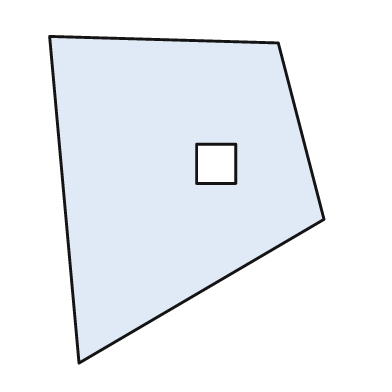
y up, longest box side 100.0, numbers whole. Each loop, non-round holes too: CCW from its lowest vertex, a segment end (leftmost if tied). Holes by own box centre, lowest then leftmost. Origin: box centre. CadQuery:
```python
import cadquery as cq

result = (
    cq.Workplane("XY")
    .moveTo(-33.0, -50.0)
    .lineTo(42.0, -6.0)
    .lineTo(28.0, 48.0)
    .lineTo(-42.0, 50.0)
    .close()
    .moveTo(3.0, 5.0)
    .lineTo(15.0, 5.0)
    .lineTo(15.0, 17.0)
    .lineTo(3.0, 17.0)
    .close()
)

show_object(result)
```